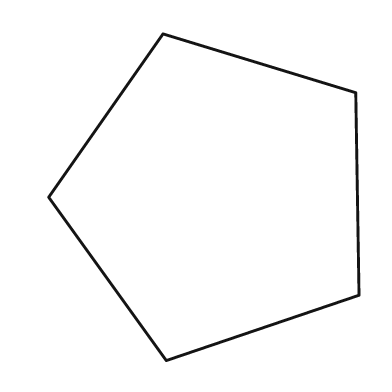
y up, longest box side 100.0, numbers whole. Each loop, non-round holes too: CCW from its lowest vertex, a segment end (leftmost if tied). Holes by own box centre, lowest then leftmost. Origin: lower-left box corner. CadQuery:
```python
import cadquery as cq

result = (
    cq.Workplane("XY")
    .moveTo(36.0, 0.0)
    .lineTo(95.0, 20.0)
    .lineTo(94.0, 82.0)
    .lineTo(35.0, 100.0)
    .lineTo(0.0, 50.0)
    .close()
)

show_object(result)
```